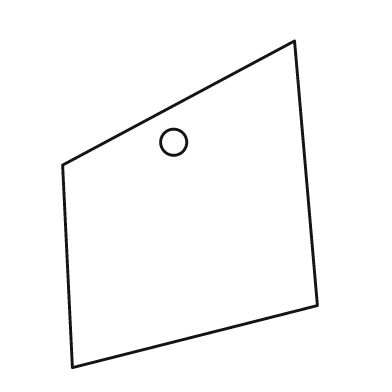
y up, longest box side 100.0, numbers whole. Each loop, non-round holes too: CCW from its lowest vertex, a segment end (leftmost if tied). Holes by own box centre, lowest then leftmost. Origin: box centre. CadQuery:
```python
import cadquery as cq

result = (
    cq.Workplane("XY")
    .moveTo(-36.0, -50.0)
    .lineTo(39.0, -31.0)
    .lineTo(32.0, 50.0)
    .lineTo(-39.0, 12.0)
    .close()
    .moveTo(-5.0, 19.0)
    .circle(4.0)
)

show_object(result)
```